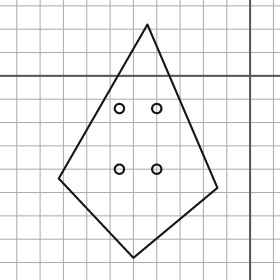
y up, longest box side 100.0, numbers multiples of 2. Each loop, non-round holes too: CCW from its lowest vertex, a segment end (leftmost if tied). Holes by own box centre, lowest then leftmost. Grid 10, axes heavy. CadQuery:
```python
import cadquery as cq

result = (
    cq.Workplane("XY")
    .moveTo(-50.0, -78.0)
    .lineTo(-14.0, -48.0)
    .lineTo(-44.0, 22.0)
    .lineTo(-82.0, -44.0)
    .close()
    .moveTo(-56.0, -40.0)
    .circle(2.0)
    .moveTo(-40.0, -40.0)
    .circle(2.0)
    .moveTo(-56.0, -14.0)
    .circle(2.0)
    .moveTo(-40.0, -14.0)
    .circle(2.0)
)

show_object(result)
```